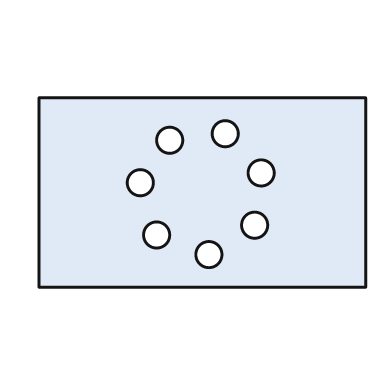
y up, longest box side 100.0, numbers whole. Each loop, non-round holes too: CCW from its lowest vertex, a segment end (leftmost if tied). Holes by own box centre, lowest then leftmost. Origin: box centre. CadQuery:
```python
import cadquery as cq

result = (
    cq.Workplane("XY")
    .moveTo(-50.0, -29.0)
    .lineTo(50.0, -29.0)
    .lineTo(50.0, 29.0)
    .lineTo(-50.0, 29.0)
    .close()
    .moveTo(2.0, -19.0)
    .circle(4.0)
    .moveTo(-14.0, -13.0)
    .circle(4.0)
    .moveTo(16.0, -10.0)
    .circle(4.0)
    .moveTo(-19.0, 3.0)
    .circle(4.0)
    .moveTo(18.0, 6.0)
    .circle(4.0)
    .moveTo(-10.0, 16.0)
    .circle(4.0)
    .moveTo(7.0, 18.0)
    .circle(4.0)
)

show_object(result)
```